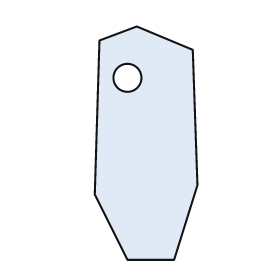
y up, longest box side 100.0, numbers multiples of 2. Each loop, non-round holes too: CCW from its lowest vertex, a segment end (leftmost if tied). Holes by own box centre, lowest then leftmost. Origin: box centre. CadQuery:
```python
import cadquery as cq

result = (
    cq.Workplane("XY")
    .moveTo(-8.0, -50.0)
    .lineTo(12.0, -50.0)
    .lineTo(22.0, -18.0)
    .lineTo(20.0, 40.0)
    .lineTo(-4.0, 50.0)
    .lineTo(-20.0, 44.0)
    .lineTo(-22.0, -22.0)
    .close()
    .moveTo(-8.0, 28.0)
    .circle(6.0)
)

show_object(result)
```